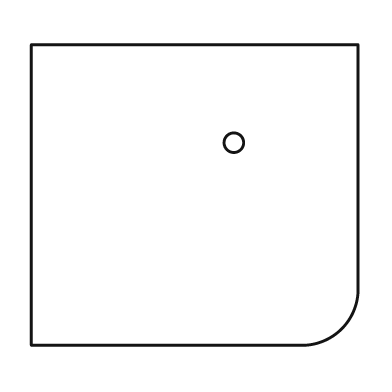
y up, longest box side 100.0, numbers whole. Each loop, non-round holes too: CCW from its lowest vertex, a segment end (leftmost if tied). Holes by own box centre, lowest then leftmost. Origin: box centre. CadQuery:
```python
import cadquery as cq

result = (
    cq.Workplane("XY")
    .moveTo(-50.0, -46.0)
    .lineTo(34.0, -46.0)
    .threePointArc((45.0, -41.0), (50.0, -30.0))
    .lineTo(50.0, 46.0)
    .lineTo(-50.0, 46.0)
    .close()
    .moveTo(12.0, 16.0)
    .circle(3.0)
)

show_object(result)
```